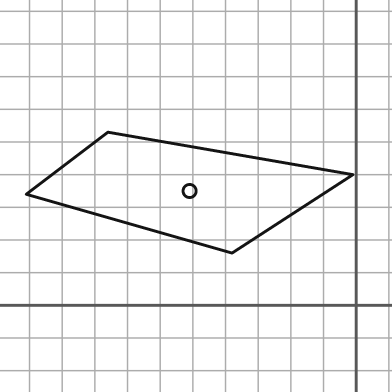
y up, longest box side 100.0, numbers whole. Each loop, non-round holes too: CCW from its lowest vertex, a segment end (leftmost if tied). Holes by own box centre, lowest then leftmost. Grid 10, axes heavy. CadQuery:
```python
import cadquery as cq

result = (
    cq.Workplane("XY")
    .moveTo(-38.0, 16.0)
    .lineTo(-1.0, 40.0)
    .lineTo(-76.0, 53.0)
    .lineTo(-101.0, 34.0)
    .close()
    .moveTo(-51.0, 35.0)
    .circle(2.0)
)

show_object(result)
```